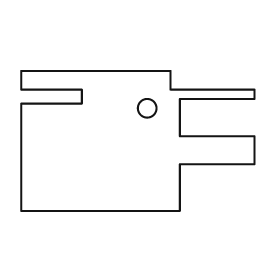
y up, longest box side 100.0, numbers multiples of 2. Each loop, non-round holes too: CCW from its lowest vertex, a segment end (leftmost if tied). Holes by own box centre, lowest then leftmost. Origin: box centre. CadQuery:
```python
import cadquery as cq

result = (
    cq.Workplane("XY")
    .moveTo(-50.0, -30.0)
    .lineTo(18.0, -30.0)
    .lineTo(18.0, -10.0)
    .lineTo(50.0, -10.0)
    .lineTo(50.0, 2.0)
    .lineTo(18.0, 2.0)
    .lineTo(18.0, 18.0)
    .lineTo(50.0, 18.0)
    .lineTo(50.0, 22.0)
    .lineTo(14.0, 22.0)
    .lineTo(14.0, 30.0)
    .lineTo(-50.0, 30.0)
    .lineTo(-50.0, 22.0)
    .lineTo(-24.0, 22.0)
    .lineTo(-24.0, 16.0)
    .lineTo(-50.0, 16.0)
    .close()
    .moveTo(4.0, 14.0)
    .circle(4.0)
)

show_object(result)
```